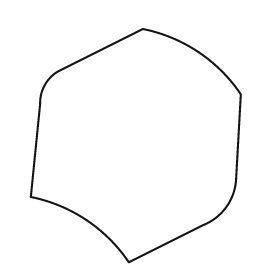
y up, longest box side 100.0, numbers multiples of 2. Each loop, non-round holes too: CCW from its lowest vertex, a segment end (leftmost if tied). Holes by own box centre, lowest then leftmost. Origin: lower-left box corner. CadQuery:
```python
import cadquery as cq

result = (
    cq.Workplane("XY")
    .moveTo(42.0, 0.0)
    .lineTo(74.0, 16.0)
    .threePointArc((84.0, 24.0), (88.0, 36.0))
    .lineTo(90.0, 72.0)
    .threePointArc((72.0, 90.0), (48.0, 100.0))
    .lineTo(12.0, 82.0)
    .threePointArc((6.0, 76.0), (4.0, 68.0))
    .lineTo(0.0, 28.0)
    .threePointArc((24.0, 18.0), (42.0, 0.0))
    .close()
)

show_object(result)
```